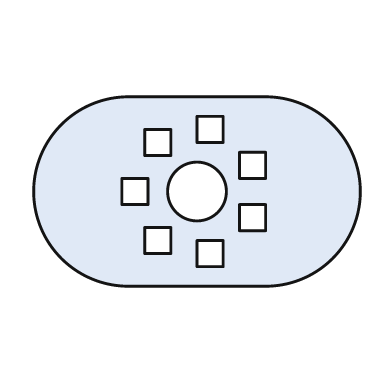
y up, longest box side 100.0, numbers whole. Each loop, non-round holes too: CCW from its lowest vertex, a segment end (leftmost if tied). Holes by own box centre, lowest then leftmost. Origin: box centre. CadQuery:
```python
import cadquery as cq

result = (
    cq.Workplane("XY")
    .moveTo(-21.0, -29.0)
    .lineTo(21.0, -29.0)
    .threePointArc((50.0, 0.0), (21.0, 29.0))
    .lineTo(-21.0, 29.0)
    .threePointArc((-50.0, 0.0), (-21.0, -29.0))
    .close()
    .moveTo(0.0, -23.0)
    .lineTo(8.0, -23.0)
    .lineTo(8.0, -15.0)
    .lineTo(0.0, -15.0)
    .close()
    .moveTo(-16.0, -19.0)
    .lineTo(-8.0, -19.0)
    .lineTo(-8.0, -11.0)
    .lineTo(-16.0, -11.0)
    .close()
    .moveTo(13.0, -12.0)
    .lineTo(21.0, -12.0)
    .lineTo(21.0, -4.0)
    .lineTo(13.0, -4.0)
    .close()
    .moveTo(-23.0, -4.0)
    .lineTo(-15.0, -4.0)
    .lineTo(-15.0, 4.0)
    .lineTo(-23.0, 4.0)
    .close()
    .moveTo(0.0, 0.0)
    .circle(9.0)
    .moveTo(13.0, 4.0)
    .lineTo(21.0, 4.0)
    .lineTo(21.0, 12.0)
    .lineTo(13.0, 12.0)
    .close()
    .moveTo(-16.0, 11.0)
    .lineTo(-8.0, 11.0)
    .lineTo(-8.0, 19.0)
    .lineTo(-16.0, 19.0)
    .close()
    .moveTo(0.0, 15.0)
    .lineTo(8.0, 15.0)
    .lineTo(8.0, 23.0)
    .lineTo(0.0, 23.0)
    .close()
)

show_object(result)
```